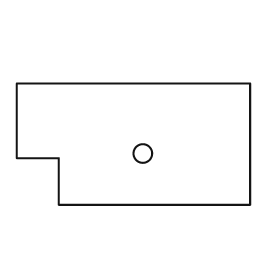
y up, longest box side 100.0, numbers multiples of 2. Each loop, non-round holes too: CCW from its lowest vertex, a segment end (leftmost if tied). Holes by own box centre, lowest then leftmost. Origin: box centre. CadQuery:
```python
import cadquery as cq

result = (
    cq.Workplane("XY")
    .moveTo(-32.0, -26.0)
    .lineTo(50.0, -26.0)
    .lineTo(50.0, 26.0)
    .lineTo(-50.0, 26.0)
    .lineTo(-50.0, -6.0)
    .lineTo(-32.0, -6.0)
    .close()
    .moveTo(4.0, -4.0)
    .circle(4.0)
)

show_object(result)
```